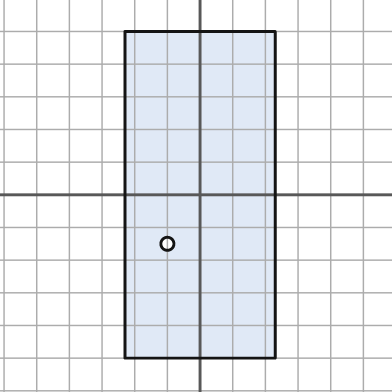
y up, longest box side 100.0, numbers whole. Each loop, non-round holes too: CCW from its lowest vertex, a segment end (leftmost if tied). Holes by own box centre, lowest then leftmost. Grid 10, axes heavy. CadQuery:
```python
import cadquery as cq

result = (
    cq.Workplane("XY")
    .moveTo(-23.0, -50.0)
    .lineTo(23.0, -50.0)
    .lineTo(23.0, 50.0)
    .lineTo(-23.0, 50.0)
    .close()
    .moveTo(-10.0, -15.0)
    .circle(2.0)
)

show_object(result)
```